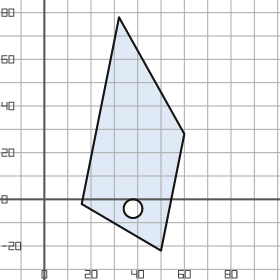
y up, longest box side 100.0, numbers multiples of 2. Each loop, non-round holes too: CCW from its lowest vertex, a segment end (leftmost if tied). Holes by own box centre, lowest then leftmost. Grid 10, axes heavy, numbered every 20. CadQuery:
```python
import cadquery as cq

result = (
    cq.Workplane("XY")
    .moveTo(50.0, -22.0)
    .lineTo(60.0, 28.0)
    .lineTo(32.0, 78.0)
    .lineTo(16.0, -2.0)
    .close()
    .moveTo(38.0, -4.0)
    .circle(4.0)
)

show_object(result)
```